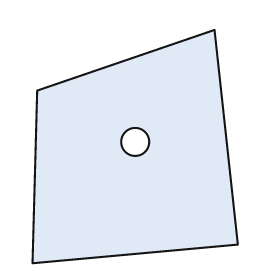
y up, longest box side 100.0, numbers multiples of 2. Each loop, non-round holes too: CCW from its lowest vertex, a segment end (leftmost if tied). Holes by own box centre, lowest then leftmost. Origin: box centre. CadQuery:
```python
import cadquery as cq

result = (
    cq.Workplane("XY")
    .moveTo(-44.0, -50.0)
    .lineTo(44.0, -42.0)
    .lineTo(34.0, 50.0)
    .lineTo(-42.0, 24.0)
    .close()
    .moveTo(0.0, 2.0)
    .circle(6.0)
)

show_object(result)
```